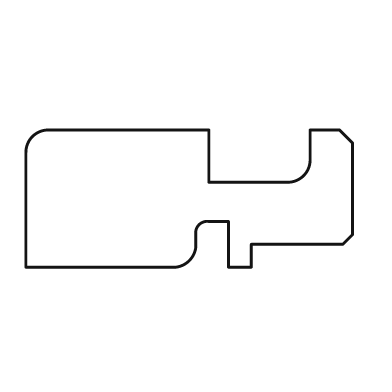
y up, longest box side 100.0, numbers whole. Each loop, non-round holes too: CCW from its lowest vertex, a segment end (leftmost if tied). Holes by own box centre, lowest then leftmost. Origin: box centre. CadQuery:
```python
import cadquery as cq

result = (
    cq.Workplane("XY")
    .moveTo(-50.0, -21.0)
    .lineTo(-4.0, -21.0)
    .threePointArc((0.0, -19.0), (2.0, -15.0))
    .lineTo(2.0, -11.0)
    .threePointArc((3.0, -8.0), (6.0, -7.0))
    .lineTo(12.0, -7.0)
    .lineTo(12.0, -21.0)
    .lineTo(19.0, -21.0)
    .lineTo(19.0, -14.0)
    .lineTo(47.0, -14.0)
    .lineTo(50.0, -11.0)
    .lineTo(50.0, 17.0)
    .lineTo(46.0, 21.0)
    .lineTo(37.0, 21.0)
    .lineTo(37.0, 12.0)
    .threePointArc((35.0, 7.0), (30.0, 5.0))
    .lineTo(6.0, 5.0)
    .lineTo(6.0, 21.0)
    .lineTo(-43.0, 21.0)
    .threePointArc((-48.0, 19.0), (-50.0, 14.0))
    .close()
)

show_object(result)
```